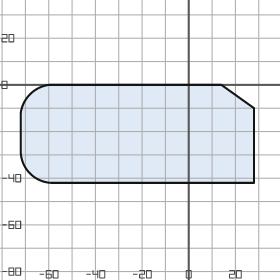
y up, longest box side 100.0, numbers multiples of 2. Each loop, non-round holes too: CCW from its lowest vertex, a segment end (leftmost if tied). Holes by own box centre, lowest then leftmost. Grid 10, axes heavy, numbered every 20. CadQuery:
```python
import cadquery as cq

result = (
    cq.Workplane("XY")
    .moveTo(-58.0, -42.0)
    .lineTo(28.0, -42.0)
    .lineTo(28.0, -10.0)
    .lineTo(14.0, 0.0)
    .lineTo(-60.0, 0.0)
    .threePointArc((-68.0, -4.0), (-72.0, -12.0))
    .lineTo(-72.0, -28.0)
    .threePointArc((-68.0, -38.0), (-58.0, -42.0))
    .close()
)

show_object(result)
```